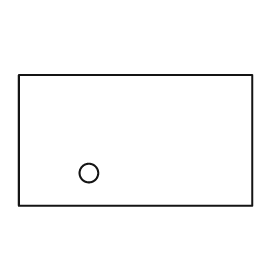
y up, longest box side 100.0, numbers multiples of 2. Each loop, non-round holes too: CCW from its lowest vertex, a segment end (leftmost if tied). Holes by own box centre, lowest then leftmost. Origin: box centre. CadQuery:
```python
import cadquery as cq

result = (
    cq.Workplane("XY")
    .moveTo(-50.0, -28.0)
    .lineTo(50.0, -28.0)
    .lineTo(50.0, 28.0)
    .lineTo(-50.0, 28.0)
    .close()
    .moveTo(-20.0, -14.0)
    .circle(4.0)
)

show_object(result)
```